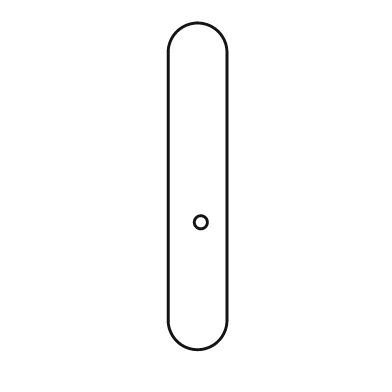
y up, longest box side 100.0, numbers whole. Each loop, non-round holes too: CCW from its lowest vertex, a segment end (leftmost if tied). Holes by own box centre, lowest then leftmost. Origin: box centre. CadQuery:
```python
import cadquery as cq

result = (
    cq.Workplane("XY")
    .moveTo(-9.0, -41.0)
    .threePointArc((0.0, -50.0), (9.0, -41.0))
    .lineTo(9.0, 41.0)
    .threePointArc((0.0, 50.0), (-9.0, 41.0))
    .close()
    .moveTo(1.0, -11.0)
    .circle(2.0)
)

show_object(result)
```